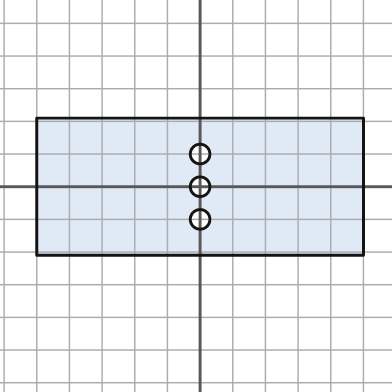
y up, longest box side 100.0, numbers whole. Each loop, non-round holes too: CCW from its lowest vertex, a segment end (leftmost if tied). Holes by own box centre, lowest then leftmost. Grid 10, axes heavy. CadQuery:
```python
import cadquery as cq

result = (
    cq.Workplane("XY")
    .moveTo(-50.0, -21.0)
    .lineTo(50.0, -21.0)
    .lineTo(50.0, 21.0)
    .lineTo(-50.0, 21.0)
    .close()
    .moveTo(0.0, -10.0)
    .circle(3.0)
    .moveTo(0.0, 0.0)
    .circle(3.0)
    .moveTo(0.0, 10.0)
    .circle(3.0)
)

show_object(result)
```